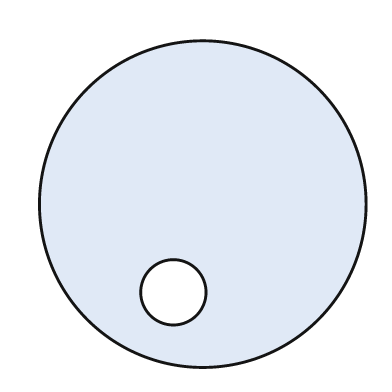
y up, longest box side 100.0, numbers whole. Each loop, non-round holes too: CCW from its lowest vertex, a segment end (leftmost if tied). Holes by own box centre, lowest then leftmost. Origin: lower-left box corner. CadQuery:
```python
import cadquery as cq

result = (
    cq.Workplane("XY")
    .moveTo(50.0, 50.0)
    .circle(50.0)
    .moveTo(41.0, 23.0)
    .circle(10.0)
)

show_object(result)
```